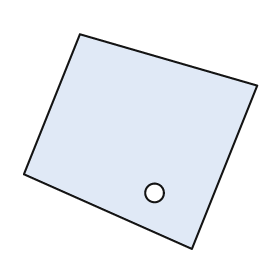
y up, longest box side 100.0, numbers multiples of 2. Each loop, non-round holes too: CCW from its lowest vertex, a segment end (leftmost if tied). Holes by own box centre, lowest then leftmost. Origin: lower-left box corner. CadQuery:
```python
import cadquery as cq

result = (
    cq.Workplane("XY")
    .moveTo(72.0, 0.0)
    .lineTo(100.0, 70.0)
    .lineTo(24.0, 92.0)
    .lineTo(0.0, 32.0)
    .close()
    .moveTo(56.0, 24.0)
    .circle(4.0)
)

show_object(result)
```